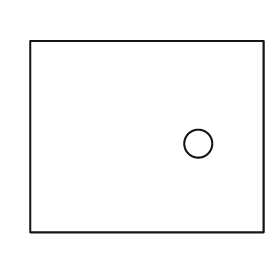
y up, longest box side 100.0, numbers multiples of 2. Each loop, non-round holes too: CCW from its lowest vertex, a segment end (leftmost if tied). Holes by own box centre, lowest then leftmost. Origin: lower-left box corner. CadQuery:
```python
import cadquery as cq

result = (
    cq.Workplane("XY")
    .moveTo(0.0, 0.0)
    .lineTo(100.0, 0.0)
    .lineTo(100.0, 82.0)
    .lineTo(0.0, 82.0)
    .close()
    .moveTo(72.0, 38.0)
    .circle(6.0)
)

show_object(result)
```